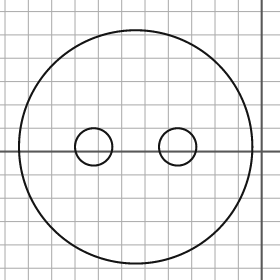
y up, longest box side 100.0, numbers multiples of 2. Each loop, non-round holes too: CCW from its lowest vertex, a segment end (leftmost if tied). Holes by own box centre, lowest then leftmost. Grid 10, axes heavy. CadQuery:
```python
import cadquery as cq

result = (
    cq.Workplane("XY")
    .moveTo(-54.0, 2.0)
    .circle(50.0)
    .moveTo(-72.0, 2.0)
    .circle(8.0)
    .moveTo(-36.0, 2.0)
    .circle(8.0)
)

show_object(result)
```